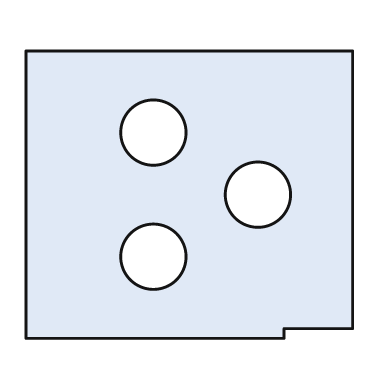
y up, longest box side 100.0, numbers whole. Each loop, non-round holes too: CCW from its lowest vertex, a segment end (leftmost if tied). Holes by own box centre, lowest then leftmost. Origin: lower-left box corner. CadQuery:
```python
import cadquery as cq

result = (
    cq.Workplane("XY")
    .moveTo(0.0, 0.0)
    .lineTo(79.0, 0.0)
    .lineTo(79.0, 3.0)
    .lineTo(100.0, 3.0)
    .lineTo(100.0, 88.0)
    .lineTo(0.0, 88.0)
    .close()
    .moveTo(39.0, 25.0)
    .circle(10.0)
    .moveTo(71.0, 44.0)
    .circle(10.0)
    .moveTo(39.0, 63.0)
    .circle(10.0)
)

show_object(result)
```